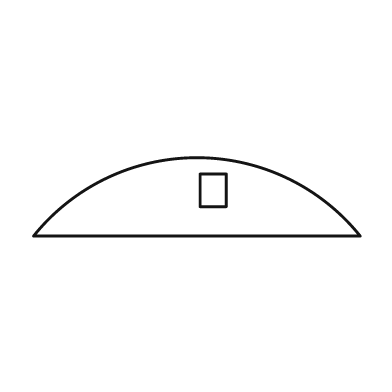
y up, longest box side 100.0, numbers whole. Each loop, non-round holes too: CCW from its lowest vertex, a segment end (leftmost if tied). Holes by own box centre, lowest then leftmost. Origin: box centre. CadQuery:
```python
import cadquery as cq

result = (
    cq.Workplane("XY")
    .moveTo(-50.0, -12.0)
    .lineTo(50.0, -12.0)
    .threePointArc((0.0, 12.0), (-50.0, -12.0))
    .close()
    .moveTo(1.0, -3.0)
    .lineTo(9.0, -3.0)
    .lineTo(9.0, 7.0)
    .lineTo(1.0, 7.0)
    .close()
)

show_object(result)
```